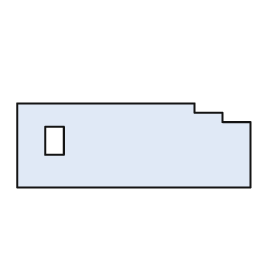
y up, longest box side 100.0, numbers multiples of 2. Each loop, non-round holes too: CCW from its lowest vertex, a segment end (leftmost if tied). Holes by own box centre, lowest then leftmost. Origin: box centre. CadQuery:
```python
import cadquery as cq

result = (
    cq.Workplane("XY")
    .moveTo(-50.0, -18.0)
    .lineTo(50.0, -18.0)
    .lineTo(50.0, 10.0)
    .lineTo(38.0, 10.0)
    .lineTo(38.0, 14.0)
    .lineTo(26.0, 14.0)
    .lineTo(26.0, 18.0)
    .lineTo(-50.0, 18.0)
    .close()
    .moveTo(-38.0, -4.0)
    .lineTo(-30.0, -4.0)
    .lineTo(-30.0, 8.0)
    .lineTo(-38.0, 8.0)
    .close()
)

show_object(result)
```